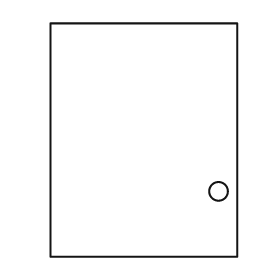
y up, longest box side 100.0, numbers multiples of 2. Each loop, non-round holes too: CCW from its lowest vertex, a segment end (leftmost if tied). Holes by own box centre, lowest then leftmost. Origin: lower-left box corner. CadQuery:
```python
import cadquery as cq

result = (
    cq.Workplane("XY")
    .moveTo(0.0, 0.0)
    .lineTo(80.0, 0.0)
    .lineTo(80.0, 100.0)
    .lineTo(0.0, 100.0)
    .close()
    .moveTo(72.0, 28.0)
    .circle(4.0)
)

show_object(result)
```